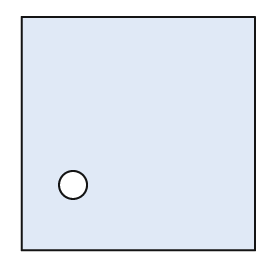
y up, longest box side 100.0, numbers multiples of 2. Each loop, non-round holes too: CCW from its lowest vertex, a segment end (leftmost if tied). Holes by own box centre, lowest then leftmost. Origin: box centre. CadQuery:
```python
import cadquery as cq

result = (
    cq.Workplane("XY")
    .moveTo(-50.0, -50.0)
    .lineTo(50.0, -50.0)
    .lineTo(50.0, 50.0)
    .lineTo(-50.0, 50.0)
    .close()
    .moveTo(-28.0, -22.0)
    .circle(6.0)
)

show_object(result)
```